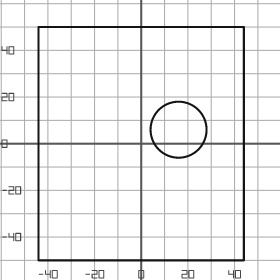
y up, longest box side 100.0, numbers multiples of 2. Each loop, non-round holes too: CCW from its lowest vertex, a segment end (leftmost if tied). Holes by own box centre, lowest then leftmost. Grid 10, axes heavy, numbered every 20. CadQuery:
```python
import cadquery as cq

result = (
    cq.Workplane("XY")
    .moveTo(-44.0, -50.0)
    .lineTo(44.0, -50.0)
    .lineTo(44.0, 50.0)
    .lineTo(-44.0, 50.0)
    .close()
    .moveTo(16.0, 6.0)
    .circle(12.0)
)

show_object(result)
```